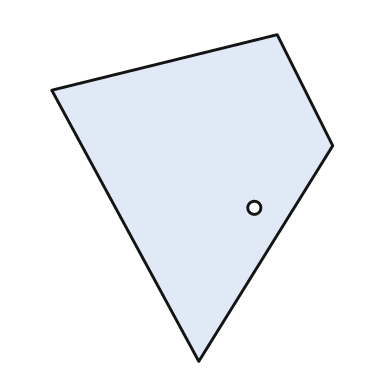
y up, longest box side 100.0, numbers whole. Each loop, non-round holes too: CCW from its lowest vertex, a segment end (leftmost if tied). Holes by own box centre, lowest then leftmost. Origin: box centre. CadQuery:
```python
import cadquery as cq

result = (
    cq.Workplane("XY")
    .moveTo(2.0, -50.0)
    .lineTo(43.0, 16.0)
    .lineTo(26.0, 50.0)
    .lineTo(-43.0, 33.0)
    .close()
    .moveTo(19.0, -3.0)
    .circle(2.0)
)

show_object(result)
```